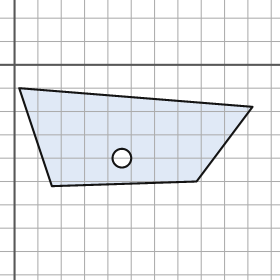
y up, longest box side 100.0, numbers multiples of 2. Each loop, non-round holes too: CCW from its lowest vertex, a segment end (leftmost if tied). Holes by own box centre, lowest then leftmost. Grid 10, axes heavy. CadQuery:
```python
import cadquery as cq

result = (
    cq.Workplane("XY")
    .moveTo(16.0, -52.0)
    .lineTo(78.0, -50.0)
    .lineTo(102.0, -18.0)
    .lineTo(2.0, -10.0)
    .close()
    .moveTo(46.0, -40.0)
    .circle(4.0)
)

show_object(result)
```